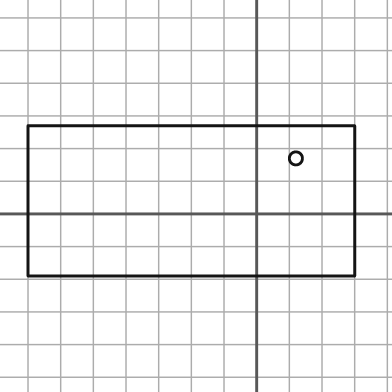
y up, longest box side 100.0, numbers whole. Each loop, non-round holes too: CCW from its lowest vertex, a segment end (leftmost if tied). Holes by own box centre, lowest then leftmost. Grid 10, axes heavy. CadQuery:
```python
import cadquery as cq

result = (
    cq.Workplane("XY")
    .moveTo(-70.0, -19.0)
    .lineTo(30.0, -19.0)
    .lineTo(30.0, 27.0)
    .lineTo(-70.0, 27.0)
    .close()
    .moveTo(12.0, 17.0)
    .circle(2.0)
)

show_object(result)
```